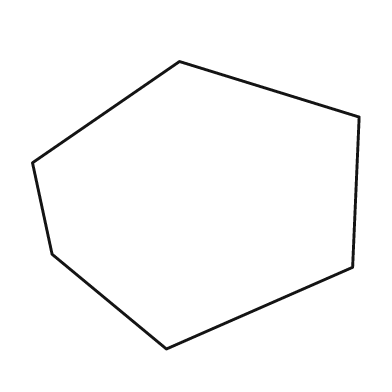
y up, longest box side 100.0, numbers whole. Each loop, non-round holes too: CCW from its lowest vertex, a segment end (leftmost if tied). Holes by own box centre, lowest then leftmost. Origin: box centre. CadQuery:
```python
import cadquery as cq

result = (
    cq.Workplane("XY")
    .moveTo(-9.0, -44.0)
    .lineTo(48.0, -19.0)
    .lineTo(50.0, 27.0)
    .lineTo(-5.0, 44.0)
    .lineTo(-50.0, 13.0)
    .lineTo(-44.0, -15.0)
    .close()
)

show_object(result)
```